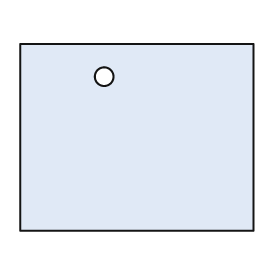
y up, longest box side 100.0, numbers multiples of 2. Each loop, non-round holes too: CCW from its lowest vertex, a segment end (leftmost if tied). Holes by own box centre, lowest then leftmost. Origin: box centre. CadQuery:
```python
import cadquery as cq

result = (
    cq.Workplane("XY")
    .moveTo(-50.0, -40.0)
    .lineTo(50.0, -40.0)
    .lineTo(50.0, 40.0)
    .lineTo(-50.0, 40.0)
    .close()
    .moveTo(-14.0, 26.0)
    .circle(4.0)
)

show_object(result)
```